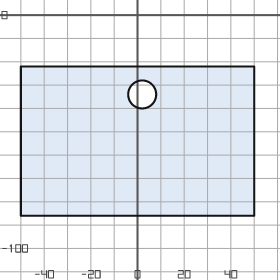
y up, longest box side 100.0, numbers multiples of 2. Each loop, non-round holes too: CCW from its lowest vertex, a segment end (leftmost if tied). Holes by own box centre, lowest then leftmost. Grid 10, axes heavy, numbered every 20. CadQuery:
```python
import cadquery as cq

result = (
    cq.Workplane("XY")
    .moveTo(-50.0, -86.0)
    .lineTo(50.0, -86.0)
    .lineTo(50.0, -22.0)
    .lineTo(-50.0, -22.0)
    .close()
    .moveTo(2.0, -34.0)
    .circle(6.0)
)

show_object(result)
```